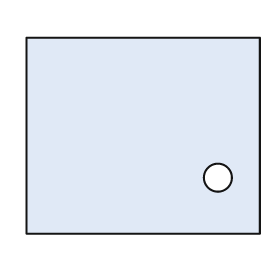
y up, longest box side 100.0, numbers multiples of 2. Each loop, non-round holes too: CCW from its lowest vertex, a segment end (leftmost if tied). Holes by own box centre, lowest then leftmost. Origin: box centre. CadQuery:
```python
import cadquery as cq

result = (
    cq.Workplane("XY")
    .moveTo(-50.0, -42.0)
    .lineTo(50.0, -42.0)
    .lineTo(50.0, 42.0)
    .lineTo(-50.0, 42.0)
    .close()
    .moveTo(32.0, -18.0)
    .circle(6.0)
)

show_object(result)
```